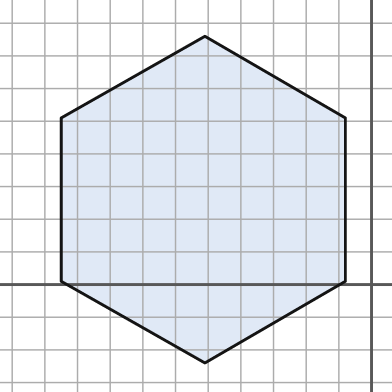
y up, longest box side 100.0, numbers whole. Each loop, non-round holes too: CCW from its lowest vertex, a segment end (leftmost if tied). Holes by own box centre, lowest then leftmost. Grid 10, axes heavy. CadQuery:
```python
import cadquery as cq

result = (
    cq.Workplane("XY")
    .moveTo(-51.0, -24.0)
    .lineTo(-8.0, 1.0)
    .lineTo(-8.0, 51.0)
    .lineTo(-51.0, 76.0)
    .lineTo(-95.0, 51.0)
    .lineTo(-95.0, 1.0)
    .close()
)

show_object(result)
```